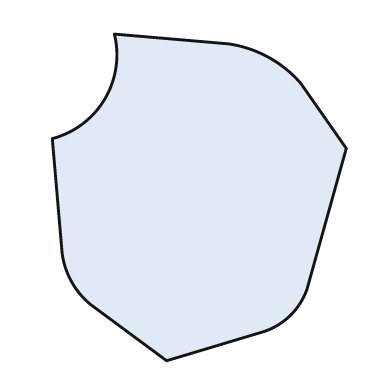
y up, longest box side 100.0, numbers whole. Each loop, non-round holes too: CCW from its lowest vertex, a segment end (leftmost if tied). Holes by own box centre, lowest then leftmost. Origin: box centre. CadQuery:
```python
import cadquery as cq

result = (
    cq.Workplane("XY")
    .moveTo(-10.0, -50.0)
    .lineTo(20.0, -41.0)
    .threePointArc((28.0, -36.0), (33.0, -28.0))
    .lineTo(45.0, 15.0)
    .lineTo(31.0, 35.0)
    .threePointArc((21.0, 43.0), (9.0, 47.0))
    .lineTo(-26.0, 50.0)
    .threePointArc((-29.0, 30.0), (-45.0, 18.0))
    .lineTo(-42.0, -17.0)
    .threePointArc((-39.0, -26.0), (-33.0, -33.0))
    .close()
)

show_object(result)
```